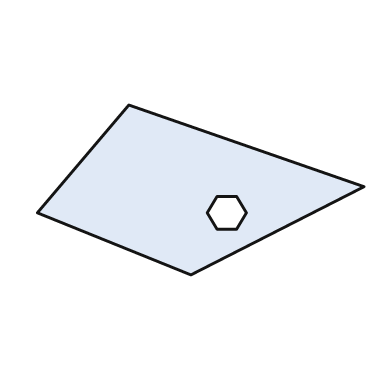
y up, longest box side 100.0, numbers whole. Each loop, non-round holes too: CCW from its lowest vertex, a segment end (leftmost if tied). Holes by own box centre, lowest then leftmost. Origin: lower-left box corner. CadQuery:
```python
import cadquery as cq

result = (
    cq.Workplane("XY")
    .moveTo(47.0, 0.0)
    .lineTo(100.0, 27.0)
    .lineTo(28.0, 52.0)
    .lineTo(0.0, 19.0)
    .close()
    .moveTo(55.0, 14.0)
    .lineTo(61.0, 14.0)
    .lineTo(64.0, 19.0)
    .lineTo(61.0, 24.0)
    .lineTo(55.0, 24.0)
    .lineTo(52.0, 19.0)
    .close()
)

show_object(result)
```